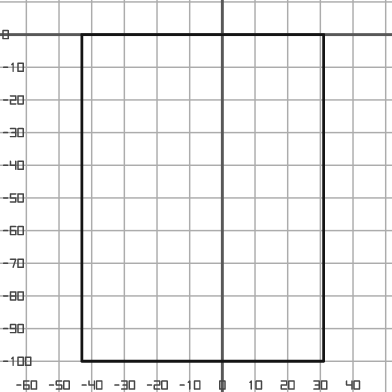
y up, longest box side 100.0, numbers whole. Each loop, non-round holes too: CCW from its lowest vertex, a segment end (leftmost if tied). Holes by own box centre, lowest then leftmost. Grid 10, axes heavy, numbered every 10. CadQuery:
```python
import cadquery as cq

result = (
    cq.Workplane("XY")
    .moveTo(-43.0, -100.0)
    .lineTo(31.0, -100.0)
    .lineTo(31.0, 0.0)
    .lineTo(-43.0, 0.0)
    .close()
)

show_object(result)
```